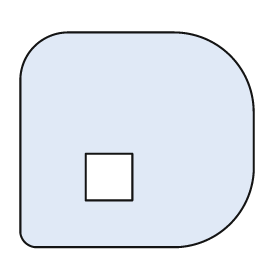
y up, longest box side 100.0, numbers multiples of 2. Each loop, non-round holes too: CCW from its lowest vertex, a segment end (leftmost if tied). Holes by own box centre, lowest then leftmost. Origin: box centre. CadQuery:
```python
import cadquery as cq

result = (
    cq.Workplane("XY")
    .moveTo(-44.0, -46.0)
    .lineTo(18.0, -46.0)
    .threePointArc((40.0, -36.0), (50.0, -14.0))
    .lineTo(50.0, 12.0)
    .threePointArc((40.0, 36.0), (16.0, 46.0))
    .lineTo(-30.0, 46.0)
    .threePointArc((-44.0, 40.0), (-50.0, 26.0))
    .lineTo(-50.0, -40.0)
    .threePointArc((-48.0, -44.0), (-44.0, -46.0))
    .close()
    .moveTo(-22.0, -26.0)
    .lineTo(-2.0, -26.0)
    .lineTo(-2.0, -6.0)
    .lineTo(-22.0, -6.0)
    .close()
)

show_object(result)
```